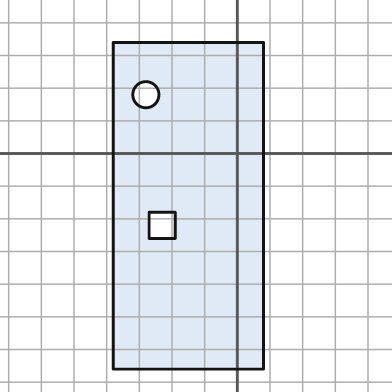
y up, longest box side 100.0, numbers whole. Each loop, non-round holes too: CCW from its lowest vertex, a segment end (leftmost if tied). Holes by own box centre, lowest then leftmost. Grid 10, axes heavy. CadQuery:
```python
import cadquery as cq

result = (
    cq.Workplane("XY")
    .moveTo(-38.0, -66.0)
    .lineTo(8.0, -66.0)
    .lineTo(8.0, 34.0)
    .lineTo(-38.0, 34.0)
    .close()
    .moveTo(-27.0, -26.0)
    .lineTo(-19.0, -26.0)
    .lineTo(-19.0, -18.0)
    .lineTo(-27.0, -18.0)
    .close()
    .moveTo(-28.0, 18.0)
    .circle(4.0)
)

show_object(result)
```